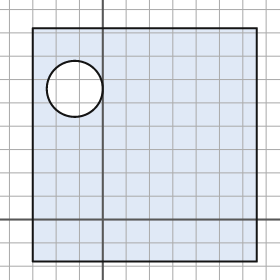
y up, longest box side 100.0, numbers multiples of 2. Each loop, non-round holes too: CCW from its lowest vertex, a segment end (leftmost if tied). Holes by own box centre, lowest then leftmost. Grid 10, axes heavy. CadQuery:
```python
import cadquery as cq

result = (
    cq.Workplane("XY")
    .moveTo(-30.0, -18.0)
    .lineTo(66.0, -18.0)
    .lineTo(66.0, 82.0)
    .lineTo(-30.0, 82.0)
    .close()
    .moveTo(-12.0, 56.0)
    .circle(12.0)
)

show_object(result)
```